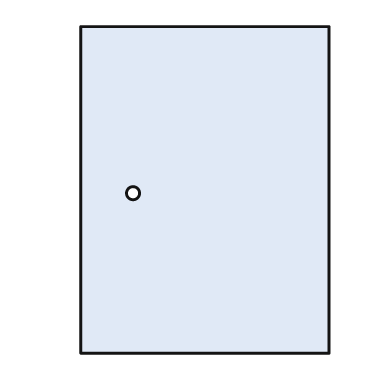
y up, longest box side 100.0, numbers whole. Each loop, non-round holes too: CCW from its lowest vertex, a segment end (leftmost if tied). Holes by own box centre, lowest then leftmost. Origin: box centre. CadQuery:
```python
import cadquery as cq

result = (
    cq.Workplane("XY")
    .moveTo(-38.0, -50.0)
    .lineTo(38.0, -50.0)
    .lineTo(38.0, 50.0)
    .lineTo(-38.0, 50.0)
    .close()
    .moveTo(-22.0, -1.0)
    .circle(2.0)
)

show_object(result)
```